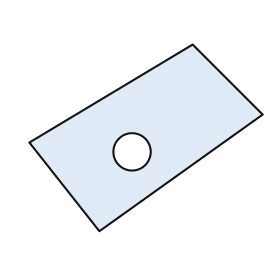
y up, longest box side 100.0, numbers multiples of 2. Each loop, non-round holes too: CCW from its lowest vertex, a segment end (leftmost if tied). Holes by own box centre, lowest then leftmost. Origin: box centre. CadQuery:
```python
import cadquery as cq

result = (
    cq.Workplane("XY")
    .moveTo(-20.0, -40.0)
    .lineTo(50.0, 10.0)
    .lineTo(20.0, 40.0)
    .lineTo(-50.0, -2.0)
    .close()
    .moveTo(-6.0, -6.0)
    .circle(8.0)
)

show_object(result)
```